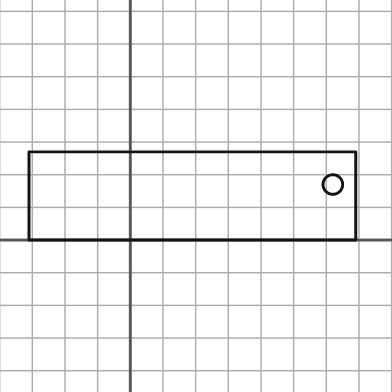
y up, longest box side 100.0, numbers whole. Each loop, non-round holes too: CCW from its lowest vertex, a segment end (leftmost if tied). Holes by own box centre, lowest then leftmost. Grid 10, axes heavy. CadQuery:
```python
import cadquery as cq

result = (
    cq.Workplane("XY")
    .moveTo(-31.0, 0.0)
    .lineTo(69.0, 0.0)
    .lineTo(69.0, 27.0)
    .lineTo(-31.0, 27.0)
    .close()
    .moveTo(62.0, 17.0)
    .circle(3.0)
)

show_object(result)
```